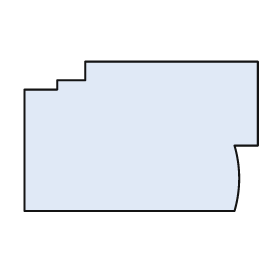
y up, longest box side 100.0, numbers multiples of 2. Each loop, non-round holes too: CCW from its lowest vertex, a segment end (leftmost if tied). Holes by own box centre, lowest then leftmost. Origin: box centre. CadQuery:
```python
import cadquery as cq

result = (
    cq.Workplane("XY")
    .moveTo(-50.0, -32.0)
    .lineTo(40.0, -32.0)
    .threePointArc((42.0, -18.0), (40.0, -4.0))
    .lineTo(50.0, -4.0)
    .lineTo(50.0, 32.0)
    .lineTo(-24.0, 32.0)
    .lineTo(-24.0, 24.0)
    .lineTo(-36.0, 24.0)
    .lineTo(-36.0, 20.0)
    .lineTo(-50.0, 20.0)
    .close()
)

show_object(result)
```